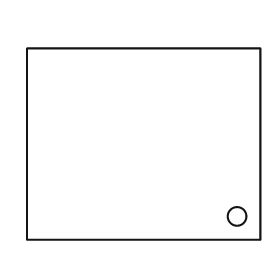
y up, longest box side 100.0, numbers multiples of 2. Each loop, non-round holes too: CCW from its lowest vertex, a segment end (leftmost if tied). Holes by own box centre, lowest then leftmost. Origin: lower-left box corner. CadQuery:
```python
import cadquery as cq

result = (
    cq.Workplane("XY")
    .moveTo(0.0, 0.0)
    .lineTo(100.0, 0.0)
    .lineTo(100.0, 82.0)
    .lineTo(0.0, 82.0)
    .close()
    .moveTo(90.0, 10.0)
    .circle(4.0)
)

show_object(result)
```